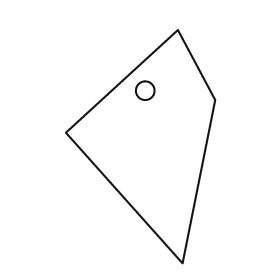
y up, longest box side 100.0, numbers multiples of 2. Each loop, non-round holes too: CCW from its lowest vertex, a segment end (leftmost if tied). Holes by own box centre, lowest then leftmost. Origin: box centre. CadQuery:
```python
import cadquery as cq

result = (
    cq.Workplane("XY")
    .moveTo(18.0, -50.0)
    .lineTo(32.0, 20.0)
    .lineTo(16.0, 50.0)
    .lineTo(-32.0, 6.0)
    .close()
    .moveTo(2.0, 24.0)
    .circle(4.0)
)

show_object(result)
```